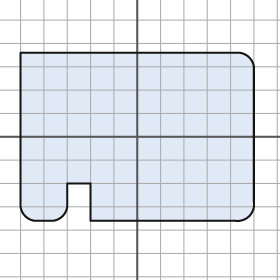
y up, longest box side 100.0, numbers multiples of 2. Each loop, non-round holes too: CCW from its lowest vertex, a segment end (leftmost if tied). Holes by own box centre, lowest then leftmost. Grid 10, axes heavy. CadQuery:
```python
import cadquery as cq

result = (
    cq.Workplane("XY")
    .moveTo(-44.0, -36.0)
    .lineTo(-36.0, -36.0)
    .threePointArc((-32.0, -34.0), (-30.0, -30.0))
    .lineTo(-30.0, -20.0)
    .lineTo(-20.0, -20.0)
    .lineTo(-20.0, -36.0)
    .lineTo(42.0, -36.0)
    .threePointArc((48.0, -34.0), (50.0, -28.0))
    .lineTo(50.0, 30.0)
    .threePointArc((48.0, 34.0), (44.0, 36.0))
    .lineTo(-50.0, 36.0)
    .lineTo(-50.0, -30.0)
    .threePointArc((-48.0, -34.0), (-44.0, -36.0))
    .close()
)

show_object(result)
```